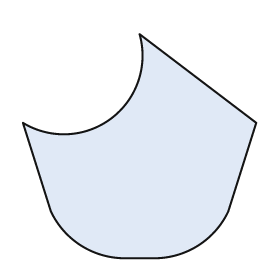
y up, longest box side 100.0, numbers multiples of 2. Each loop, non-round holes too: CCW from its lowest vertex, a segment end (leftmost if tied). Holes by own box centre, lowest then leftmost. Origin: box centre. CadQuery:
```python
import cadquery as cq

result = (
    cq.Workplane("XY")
    .moveTo(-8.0, -48.0)
    .lineTo(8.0, -48.0)
    .threePointArc((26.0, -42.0), (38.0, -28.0))
    .lineTo(50.0, 10.0)
    .lineTo(0.0, 48.0)
    .threePointArc((-12.0, 12.0), (-50.0, 10.0))
    .lineTo(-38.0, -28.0)
    .threePointArc((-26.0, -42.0), (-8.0, -48.0))
    .close()
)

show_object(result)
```